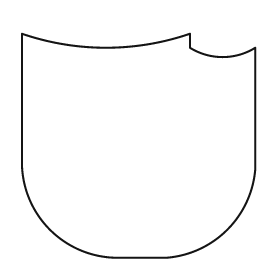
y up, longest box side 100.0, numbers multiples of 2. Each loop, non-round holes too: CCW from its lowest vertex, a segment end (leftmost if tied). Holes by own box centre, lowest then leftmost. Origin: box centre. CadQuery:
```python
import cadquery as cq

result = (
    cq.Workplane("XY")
    .moveTo(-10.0, -48.0)
    .lineTo(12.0, -48.0)
    .threePointArc((38.0, -36.0), (50.0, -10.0))
    .lineTo(50.0, 42.0)
    .threePointArc((36.0, 38.0), (22.0, 42.0))
    .lineTo(22.0, 48.0)
    .threePointArc((-14.0, 42.0), (-50.0, 48.0))
    .lineTo(-50.0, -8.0)
    .threePointArc((-38.0, -36.0), (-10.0, -48.0))
    .close()
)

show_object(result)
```